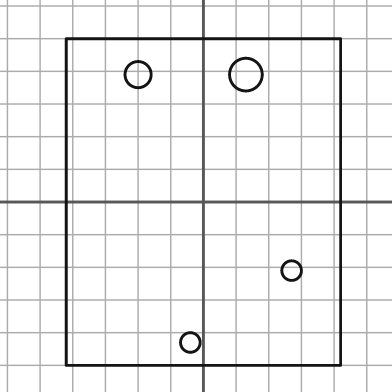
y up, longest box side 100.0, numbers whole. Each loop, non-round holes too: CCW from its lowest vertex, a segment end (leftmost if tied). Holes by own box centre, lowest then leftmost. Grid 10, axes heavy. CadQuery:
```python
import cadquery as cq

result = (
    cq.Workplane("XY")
    .moveTo(-42.0, -50.0)
    .lineTo(42.0, -50.0)
    .lineTo(42.0, 50.0)
    .lineTo(-42.0, 50.0)
    .close()
    .moveTo(-4.0, -43.0)
    .circle(3.0)
    .moveTo(27.0, -21.0)
    .circle(3.0)
    .moveTo(-20.0, 39.0)
    .circle(4.0)
    .moveTo(13.0, 39.0)
    .circle(5.0)
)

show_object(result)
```